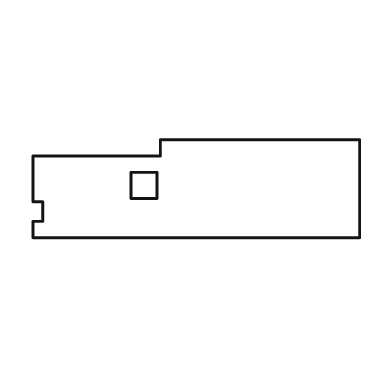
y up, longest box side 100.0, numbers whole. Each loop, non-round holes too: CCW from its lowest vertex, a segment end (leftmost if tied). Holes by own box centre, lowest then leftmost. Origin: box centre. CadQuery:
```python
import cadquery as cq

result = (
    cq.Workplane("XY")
    .moveTo(-50.0, -15.0)
    .lineTo(50.0, -15.0)
    .lineTo(50.0, 15.0)
    .lineTo(-11.0, 15.0)
    .lineTo(-11.0, 10.0)
    .lineTo(-50.0, 10.0)
    .lineTo(-50.0, -4.0)
    .lineTo(-47.0, -4.0)
    .lineTo(-47.0, -10.0)
    .lineTo(-50.0, -10.0)
    .close()
    .moveTo(-20.0, -3.0)
    .lineTo(-12.0, -3.0)
    .lineTo(-12.0, 5.0)
    .lineTo(-20.0, 5.0)
    .close()
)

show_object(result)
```